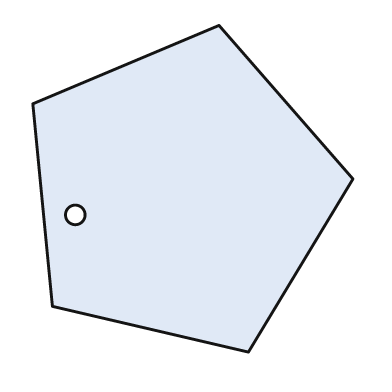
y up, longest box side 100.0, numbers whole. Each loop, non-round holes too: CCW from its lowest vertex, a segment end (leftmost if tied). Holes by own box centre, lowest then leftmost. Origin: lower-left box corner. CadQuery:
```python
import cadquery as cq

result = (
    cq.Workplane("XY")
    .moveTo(66.0, 0.0)
    .lineTo(98.0, 53.0)
    .lineTo(57.0, 100.0)
    .lineTo(0.0, 76.0)
    .lineTo(6.0, 14.0)
    .close()
    .moveTo(13.0, 42.0)
    .circle(3.0)
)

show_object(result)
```